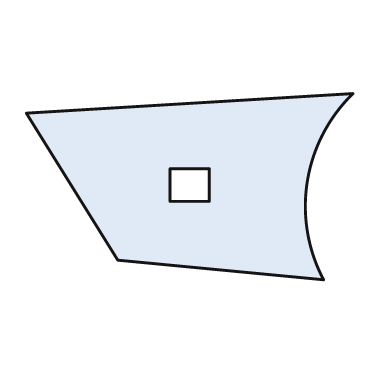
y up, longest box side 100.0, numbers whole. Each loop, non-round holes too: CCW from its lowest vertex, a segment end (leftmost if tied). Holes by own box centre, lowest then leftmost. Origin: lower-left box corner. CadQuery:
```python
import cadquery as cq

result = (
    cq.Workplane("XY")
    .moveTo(91.0, 0.0)
    .threePointArc((86.0, 30.0), (100.0, 57.0))
    .lineTo(0.0, 51.0)
    .lineTo(28.0, 6.0)
    .close()
    .moveTo(44.0, 24.0)
    .lineTo(56.0, 24.0)
    .lineTo(56.0, 34.0)
    .lineTo(44.0, 34.0)
    .close()
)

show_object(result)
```